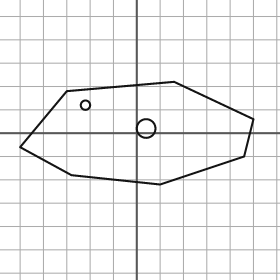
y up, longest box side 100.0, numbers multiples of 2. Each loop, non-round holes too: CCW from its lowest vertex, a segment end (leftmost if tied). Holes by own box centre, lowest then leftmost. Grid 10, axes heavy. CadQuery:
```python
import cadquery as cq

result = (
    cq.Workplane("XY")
    .moveTo(10.0, -22.0)
    .lineTo(46.0, -10.0)
    .lineTo(50.0, 6.0)
    .lineTo(16.0, 22.0)
    .lineTo(-30.0, 18.0)
    .lineTo(-50.0, -6.0)
    .lineTo(-28.0, -18.0)
    .close()
    .moveTo(4.0, 2.0)
    .circle(4.0)
    .moveTo(-22.0, 12.0)
    .circle(2.0)
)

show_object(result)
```